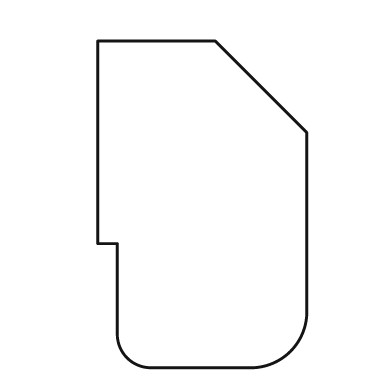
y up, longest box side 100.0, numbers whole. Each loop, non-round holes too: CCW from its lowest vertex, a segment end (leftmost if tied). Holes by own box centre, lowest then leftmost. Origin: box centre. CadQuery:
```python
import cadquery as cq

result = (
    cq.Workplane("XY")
    .moveTo(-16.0, -50.0)
    .lineTo(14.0, -50.0)
    .threePointArc((27.0, -45.0), (32.0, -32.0))
    .lineTo(32.0, 22.0)
    .lineTo(4.0, 50.0)
    .lineTo(-32.0, 50.0)
    .lineTo(-32.0, -12.0)
    .lineTo(-26.0, -12.0)
    .lineTo(-26.0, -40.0)
    .threePointArc((-23.0, -47.0), (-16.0, -50.0))
    .close()
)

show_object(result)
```